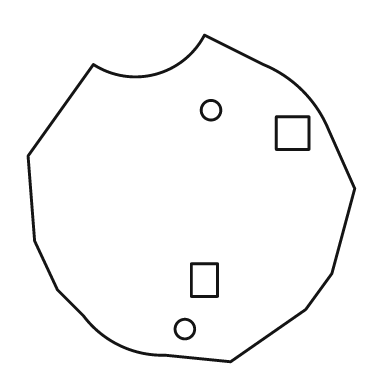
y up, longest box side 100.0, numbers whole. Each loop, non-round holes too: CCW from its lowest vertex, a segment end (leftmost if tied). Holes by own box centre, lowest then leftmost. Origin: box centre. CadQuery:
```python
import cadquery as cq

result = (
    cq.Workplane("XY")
    .moveTo(12.0, -50.0)
    .lineTo(35.0, -34.0)
    .lineTo(43.0, -23.0)
    .lineTo(50.0, 3.0)
    .lineTo(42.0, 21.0)
    .threePointArc((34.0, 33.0), (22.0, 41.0))
    .lineTo(4.0, 50.0)
    .threePointArc((-11.0, 38.0), (-30.0, 41.0))
    .lineTo(-50.0, 13.0)
    .lineTo(-48.0, -13.0)
    .lineTo(-41.0, -28.0)
    .lineTo(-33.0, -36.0)
    .threePointArc((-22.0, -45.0), (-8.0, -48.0))
    .close()
    .moveTo(-2.0, -40.0)
    .circle(3.0)
    .moveTo(0.0, -30.0)
    .lineTo(8.0, -30.0)
    .lineTo(8.0, -20.0)
    .lineTo(0.0, -20.0)
    .close()
    .moveTo(26.0, 15.0)
    .lineTo(36.0, 15.0)
    .lineTo(36.0, 25.0)
    .lineTo(26.0, 25.0)
    .close()
    .moveTo(6.0, 27.0)
    .circle(3.0)
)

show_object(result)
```